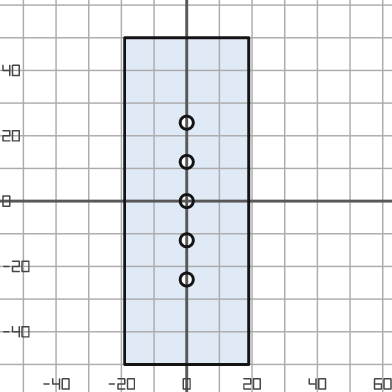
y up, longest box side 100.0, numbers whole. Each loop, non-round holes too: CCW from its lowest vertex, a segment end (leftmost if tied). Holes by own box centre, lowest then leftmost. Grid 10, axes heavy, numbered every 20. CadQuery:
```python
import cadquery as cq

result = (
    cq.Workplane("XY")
    .moveTo(-19.0, -50.0)
    .lineTo(19.0, -50.0)
    .lineTo(19.0, 50.0)
    .lineTo(-19.0, 50.0)
    .close()
    .moveTo(0.0, -24.0)
    .circle(2.0)
    .moveTo(0.0, -12.0)
    .circle(2.0)
    .moveTo(0.0, 0.0)
    .circle(2.0)
    .moveTo(0.0, 12.0)
    .circle(2.0)
    .moveTo(0.0, 24.0)
    .circle(2.0)
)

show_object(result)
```